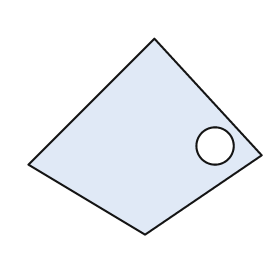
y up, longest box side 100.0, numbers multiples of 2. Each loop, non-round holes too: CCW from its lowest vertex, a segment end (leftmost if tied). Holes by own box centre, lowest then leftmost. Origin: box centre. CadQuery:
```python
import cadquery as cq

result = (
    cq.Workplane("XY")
    .moveTo(0.0, -42.0)
    .lineTo(50.0, -8.0)
    .lineTo(4.0, 42.0)
    .lineTo(-50.0, -12.0)
    .close()
    .moveTo(30.0, -4.0)
    .circle(8.0)
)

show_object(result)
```